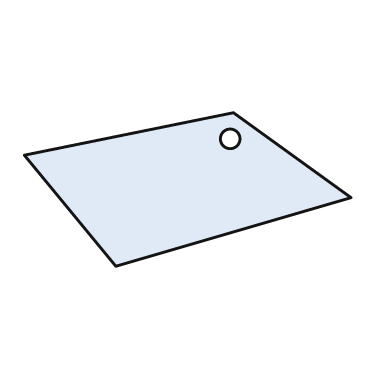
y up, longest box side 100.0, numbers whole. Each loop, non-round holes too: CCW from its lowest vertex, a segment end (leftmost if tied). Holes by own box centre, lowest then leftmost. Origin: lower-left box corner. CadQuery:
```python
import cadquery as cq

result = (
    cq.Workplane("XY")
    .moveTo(28.0, 0.0)
    .lineTo(100.0, 21.0)
    .lineTo(64.0, 47.0)
    .lineTo(0.0, 34.0)
    .close()
    .moveTo(63.0, 39.0)
    .circle(3.0)
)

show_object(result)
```